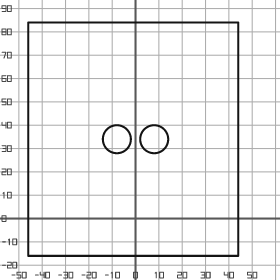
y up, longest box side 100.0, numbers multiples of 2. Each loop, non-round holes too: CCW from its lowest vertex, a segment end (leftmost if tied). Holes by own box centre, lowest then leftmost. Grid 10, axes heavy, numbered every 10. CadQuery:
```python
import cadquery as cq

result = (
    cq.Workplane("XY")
    .moveTo(-46.0, -16.0)
    .lineTo(44.0, -16.0)
    .lineTo(44.0, 84.0)
    .lineTo(-46.0, 84.0)
    .close()
    .moveTo(-8.0, 34.0)
    .circle(6.0)
    .moveTo(8.0, 34.0)
    .circle(6.0)
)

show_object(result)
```